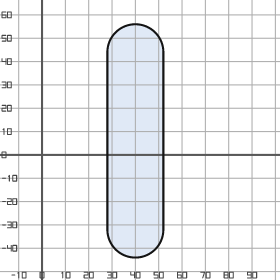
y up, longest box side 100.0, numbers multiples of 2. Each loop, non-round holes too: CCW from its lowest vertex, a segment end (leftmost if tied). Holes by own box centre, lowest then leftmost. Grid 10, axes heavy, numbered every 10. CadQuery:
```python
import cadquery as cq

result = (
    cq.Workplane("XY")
    .moveTo(28.0, -32.0)
    .threePointArc((40.0, -44.0), (52.0, -32.0))
    .lineTo(52.0, 44.0)
    .threePointArc((40.0, 56.0), (28.0, 44.0))
    .close()
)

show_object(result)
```